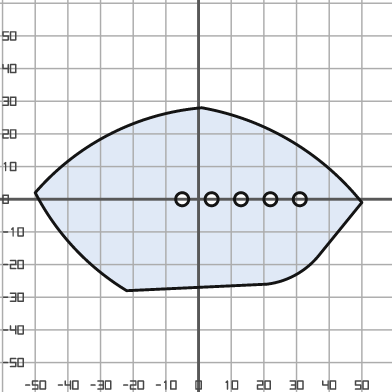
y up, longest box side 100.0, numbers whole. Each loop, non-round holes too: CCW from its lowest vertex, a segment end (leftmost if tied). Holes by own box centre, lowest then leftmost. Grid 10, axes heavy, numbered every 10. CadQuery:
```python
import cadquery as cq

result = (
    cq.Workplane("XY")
    .moveTo(-22.0, -28.0)
    .lineTo(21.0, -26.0)
    .threePointArc((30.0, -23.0), (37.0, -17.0))
    .lineTo(50.0, -1.0)
    .threePointArc((28.0, 18.0), (1.0, 28.0))
    .threePointArc((-27.0, 20.0), (-50.0, 2.0))
    .threePointArc((-38.0, -15.0), (-22.0, -28.0))
    .close()
    .moveTo(-5.0, 0.0)
    .circle(2.0)
    .moveTo(4.0, 0.0)
    .circle(2.0)
    .moveTo(13.0, 0.0)
    .circle(2.0)
    .moveTo(22.0, 0.0)
    .circle(2.0)
    .moveTo(31.0, 0.0)
    .circle(2.0)
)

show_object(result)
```